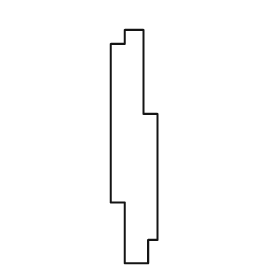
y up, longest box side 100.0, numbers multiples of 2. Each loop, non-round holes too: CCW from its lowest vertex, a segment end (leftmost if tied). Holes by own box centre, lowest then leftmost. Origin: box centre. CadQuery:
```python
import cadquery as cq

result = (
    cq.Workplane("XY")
    .moveTo(-4.0, -50.0)
    .lineTo(6.0, -50.0)
    .lineTo(6.0, -40.0)
    .lineTo(10.0, -40.0)
    .lineTo(10.0, 14.0)
    .lineTo(4.0, 14.0)
    .lineTo(4.0, 50.0)
    .lineTo(-4.0, 50.0)
    .lineTo(-4.0, 44.0)
    .lineTo(-10.0, 44.0)
    .lineTo(-10.0, -24.0)
    .lineTo(-4.0, -24.0)
    .close()
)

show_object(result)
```